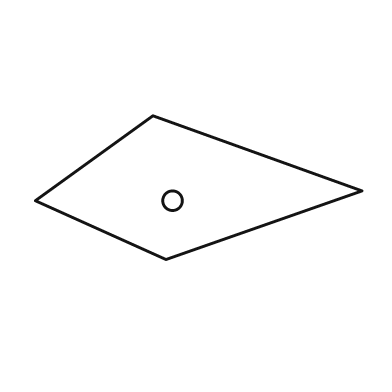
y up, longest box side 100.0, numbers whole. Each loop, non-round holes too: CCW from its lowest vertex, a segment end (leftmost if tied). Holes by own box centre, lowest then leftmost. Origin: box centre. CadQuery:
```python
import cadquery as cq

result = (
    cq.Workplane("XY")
    .moveTo(-10.0, -22.0)
    .lineTo(50.0, -1.0)
    .lineTo(-14.0, 22.0)
    .lineTo(-50.0, -4.0)
    .close()
    .moveTo(-8.0, -4.0)
    .circle(3.0)
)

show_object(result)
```